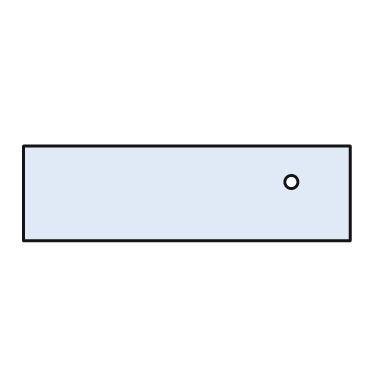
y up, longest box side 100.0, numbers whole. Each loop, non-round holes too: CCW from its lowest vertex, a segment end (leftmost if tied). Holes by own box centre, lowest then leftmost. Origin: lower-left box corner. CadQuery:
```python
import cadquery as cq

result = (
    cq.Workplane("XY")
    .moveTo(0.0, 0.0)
    .lineTo(100.0, 0.0)
    .lineTo(100.0, 29.0)
    .lineTo(0.0, 29.0)
    .close()
    .moveTo(82.0, 18.0)
    .circle(2.0)
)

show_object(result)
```